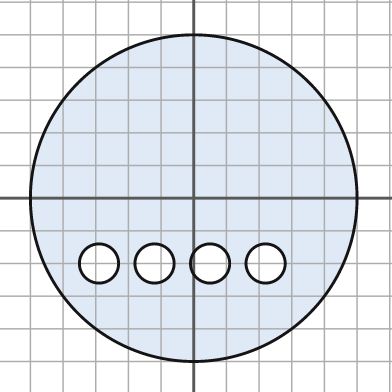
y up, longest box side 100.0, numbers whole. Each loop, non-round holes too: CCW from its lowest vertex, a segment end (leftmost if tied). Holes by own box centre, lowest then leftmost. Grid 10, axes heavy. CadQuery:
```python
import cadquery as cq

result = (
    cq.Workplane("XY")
    .moveTo(0.0, 0.0)
    .circle(50.0)
    .moveTo(-29.0, -20.0)
    .circle(6.0)
    .moveTo(-12.0, -20.0)
    .circle(6.0)
    .moveTo(5.0, -20.0)
    .circle(6.0)
    .moveTo(22.0, -20.0)
    .circle(6.0)
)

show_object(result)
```